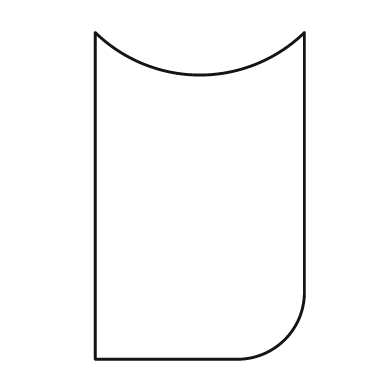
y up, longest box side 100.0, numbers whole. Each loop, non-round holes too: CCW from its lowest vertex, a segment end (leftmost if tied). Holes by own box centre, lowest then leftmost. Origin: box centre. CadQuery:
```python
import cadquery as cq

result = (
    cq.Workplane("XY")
    .moveTo(-32.0, -50.0)
    .lineTo(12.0, -50.0)
    .threePointArc((26.0, -44.0), (32.0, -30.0))
    .lineTo(32.0, 50.0)
    .threePointArc((0.0, 37.0), (-32.0, 50.0))
    .close()
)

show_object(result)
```